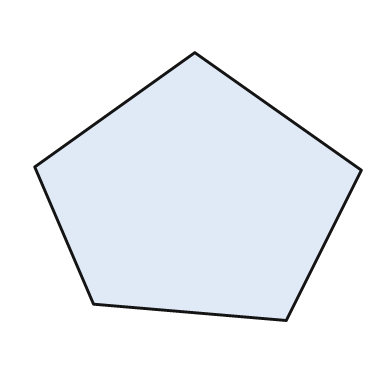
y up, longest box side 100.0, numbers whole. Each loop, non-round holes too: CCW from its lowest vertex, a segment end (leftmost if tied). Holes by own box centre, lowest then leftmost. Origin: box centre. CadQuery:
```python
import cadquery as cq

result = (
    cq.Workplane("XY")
    .moveTo(27.0, -41.0)
    .lineTo(50.0, 5.0)
    .lineTo(-1.0, 41.0)
    .lineTo(-50.0, 6.0)
    .lineTo(-32.0, -36.0)
    .close()
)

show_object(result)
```